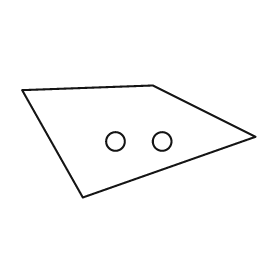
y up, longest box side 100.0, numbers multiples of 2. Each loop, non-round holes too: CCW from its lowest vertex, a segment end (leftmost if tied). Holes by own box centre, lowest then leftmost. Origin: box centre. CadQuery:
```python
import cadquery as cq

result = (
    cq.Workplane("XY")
    .moveTo(-24.0, -24.0)
    .lineTo(50.0, 2.0)
    .lineTo(6.0, 24.0)
    .lineTo(-50.0, 22.0)
    .close()
    .moveTo(-10.0, 0.0)
    .circle(4.0)
    .moveTo(10.0, 0.0)
    .circle(4.0)
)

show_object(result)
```